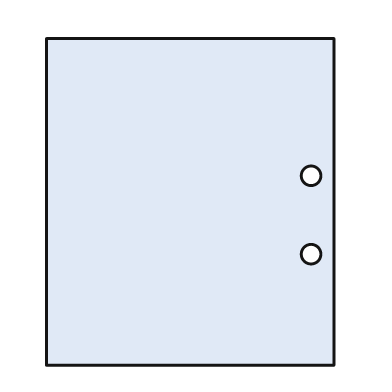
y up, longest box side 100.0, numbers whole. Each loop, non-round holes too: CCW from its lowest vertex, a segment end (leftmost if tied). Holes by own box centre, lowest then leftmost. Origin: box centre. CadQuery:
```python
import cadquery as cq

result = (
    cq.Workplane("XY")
    .moveTo(-44.0, -50.0)
    .lineTo(44.0, -50.0)
    .lineTo(44.0, 50.0)
    .lineTo(-44.0, 50.0)
    .close()
    .moveTo(37.0, -16.0)
    .circle(3.0)
    .moveTo(37.0, 8.0)
    .circle(3.0)
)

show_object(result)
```